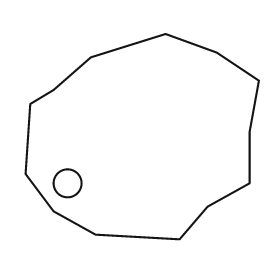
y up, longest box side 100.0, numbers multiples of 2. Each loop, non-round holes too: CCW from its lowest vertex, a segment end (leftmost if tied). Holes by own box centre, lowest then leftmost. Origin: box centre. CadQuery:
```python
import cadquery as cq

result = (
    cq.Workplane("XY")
    .moveTo(16.0, -44.0)
    .lineTo(28.0, -30.0)
    .lineTo(46.0, -20.0)
    .lineTo(46.0, 2.0)
    .lineTo(50.0, 24.0)
    .lineTo(32.0, 36.0)
    .lineTo(10.0, 44.0)
    .lineTo(-22.0, 34.0)
    .lineTo(-38.0, 20.0)
    .lineTo(-48.0, 14.0)
    .lineTo(-50.0, -16.0)
    .lineTo(-38.0, -32.0)
    .lineTo(-20.0, -42.0)
    .close()
    .moveTo(-32.0, -20.0)
    .circle(6.0)
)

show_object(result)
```